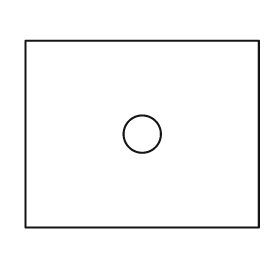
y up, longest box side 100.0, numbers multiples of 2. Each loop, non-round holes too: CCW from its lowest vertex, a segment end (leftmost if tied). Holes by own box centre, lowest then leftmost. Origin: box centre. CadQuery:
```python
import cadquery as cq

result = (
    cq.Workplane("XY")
    .moveTo(-50.0, -40.0)
    .lineTo(50.0, -40.0)
    .lineTo(50.0, 40.0)
    .lineTo(-50.0, 40.0)
    .close()
    .moveTo(0.0, 0.0)
    .circle(8.0)
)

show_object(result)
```